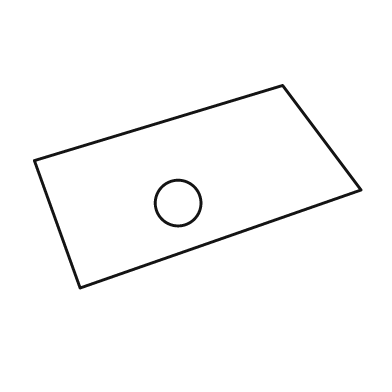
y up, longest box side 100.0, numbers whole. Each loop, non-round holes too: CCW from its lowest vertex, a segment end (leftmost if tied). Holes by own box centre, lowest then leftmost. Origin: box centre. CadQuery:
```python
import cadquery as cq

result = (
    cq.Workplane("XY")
    .moveTo(-36.0, -31.0)
    .lineTo(50.0, -1.0)
    .lineTo(26.0, 31.0)
    .lineTo(-50.0, 8.0)
    .close()
    .moveTo(-6.0, -5.0)
    .circle(7.0)
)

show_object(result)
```